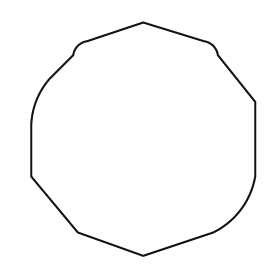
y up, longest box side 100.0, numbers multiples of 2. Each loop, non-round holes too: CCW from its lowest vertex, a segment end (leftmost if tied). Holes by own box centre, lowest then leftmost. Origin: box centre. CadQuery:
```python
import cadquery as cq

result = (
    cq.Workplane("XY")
    .moveTo(0.0, -50.0)
    .lineTo(30.0, -40.0)
    .threePointArc((42.0, -30.0), (48.0, -16.0))
    .lineTo(48.0, 16.0)
    .lineTo(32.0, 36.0)
    .threePointArc((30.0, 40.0), (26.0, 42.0))
    .lineTo(0.0, 50.0)
    .lineTo(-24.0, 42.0)
    .threePointArc((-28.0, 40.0), (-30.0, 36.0))
    .lineTo(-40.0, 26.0)
    .threePointArc((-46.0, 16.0), (-48.0, 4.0))
    .lineTo(-48.0, -16.0)
    .lineTo(-28.0, -40.0)
    .close()
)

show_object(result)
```